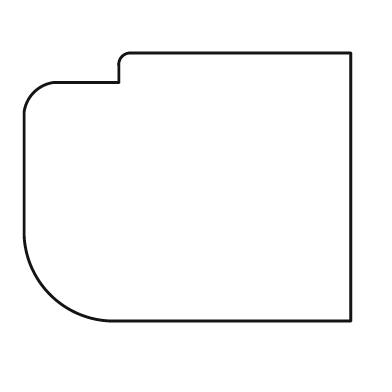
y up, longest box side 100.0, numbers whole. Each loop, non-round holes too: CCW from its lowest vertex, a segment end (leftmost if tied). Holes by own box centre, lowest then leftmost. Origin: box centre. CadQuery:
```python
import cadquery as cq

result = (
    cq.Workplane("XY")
    .moveTo(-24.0, -41.0)
    .lineTo(50.0, -41.0)
    .lineTo(50.0, 41.0)
    .lineTo(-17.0, 41.0)
    .threePointArc((-20.0, 40.0), (-21.0, 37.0))
    .lineTo(-21.0, 32.0)
    .lineTo(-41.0, 32.0)
    .threePointArc((-47.0, 29.0), (-50.0, 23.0))
    .lineTo(-50.0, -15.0)
    .threePointArc((-42.0, -33.0), (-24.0, -41.0))
    .close()
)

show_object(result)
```